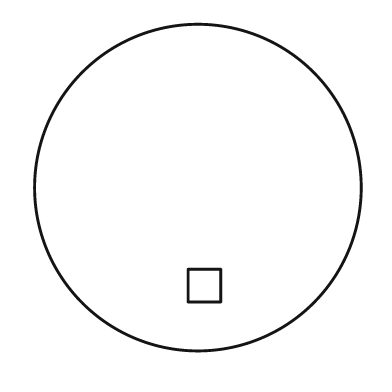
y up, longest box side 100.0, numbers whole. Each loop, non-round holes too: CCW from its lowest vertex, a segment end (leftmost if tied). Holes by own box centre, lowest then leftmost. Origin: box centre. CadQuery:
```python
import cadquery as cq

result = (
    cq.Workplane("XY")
    .moveTo(0.0, 0.0)
    .circle(50.0)
    .moveTo(-3.0, -35.0)
    .lineTo(7.0, -35.0)
    .lineTo(7.0, -25.0)
    .lineTo(-3.0, -25.0)
    .close()
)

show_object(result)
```